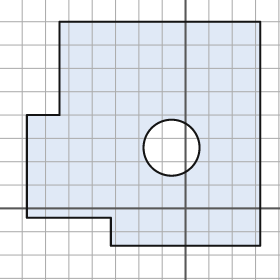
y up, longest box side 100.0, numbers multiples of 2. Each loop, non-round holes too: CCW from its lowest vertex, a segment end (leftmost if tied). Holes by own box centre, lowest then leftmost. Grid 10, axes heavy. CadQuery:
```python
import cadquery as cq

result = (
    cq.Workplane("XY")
    .moveTo(-32.0, -16.0)
    .lineTo(32.0, -16.0)
    .lineTo(32.0, 80.0)
    .lineTo(-54.0, 80.0)
    .lineTo(-54.0, 40.0)
    .lineTo(-68.0, 40.0)
    .lineTo(-68.0, -4.0)
    .lineTo(-32.0, -4.0)
    .close()
    .moveTo(-6.0, 26.0)
    .circle(12.0)
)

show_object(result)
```